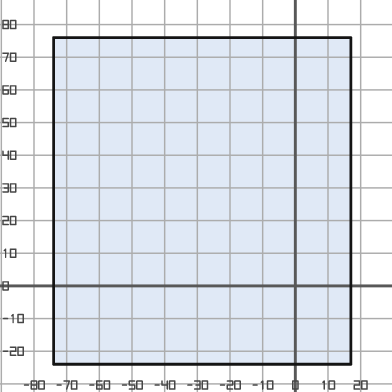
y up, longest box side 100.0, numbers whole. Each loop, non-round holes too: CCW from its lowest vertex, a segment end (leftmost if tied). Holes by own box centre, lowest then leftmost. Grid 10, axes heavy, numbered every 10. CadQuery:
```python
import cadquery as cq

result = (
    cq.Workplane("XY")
    .moveTo(-74.0, -24.0)
    .lineTo(17.0, -24.0)
    .lineTo(17.0, 76.0)
    .lineTo(-74.0, 76.0)
    .close()
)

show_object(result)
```